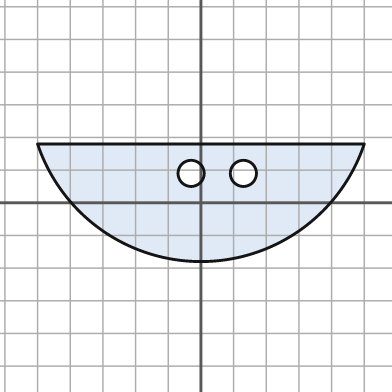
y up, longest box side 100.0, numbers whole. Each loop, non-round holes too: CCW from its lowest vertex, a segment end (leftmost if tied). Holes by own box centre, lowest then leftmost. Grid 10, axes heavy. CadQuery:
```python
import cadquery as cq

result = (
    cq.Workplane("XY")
    .moveTo(-50.0, 18.0)
    .threePointArc((0.0, -18.0), (50.0, 18.0))
    .close()
    .moveTo(-3.0, 9.0)
    .circle(4.0)
    .moveTo(13.0, 9.0)
    .circle(4.0)
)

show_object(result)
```